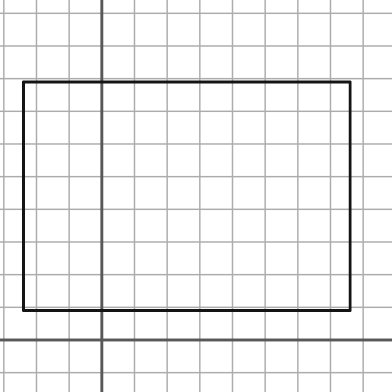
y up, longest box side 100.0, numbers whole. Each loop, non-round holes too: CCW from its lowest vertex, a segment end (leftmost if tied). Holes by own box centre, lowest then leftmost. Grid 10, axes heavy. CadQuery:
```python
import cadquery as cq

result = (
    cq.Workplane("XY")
    .moveTo(-24.0, 9.0)
    .lineTo(76.0, 9.0)
    .lineTo(76.0, 79.0)
    .lineTo(-24.0, 79.0)
    .close()
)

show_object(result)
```